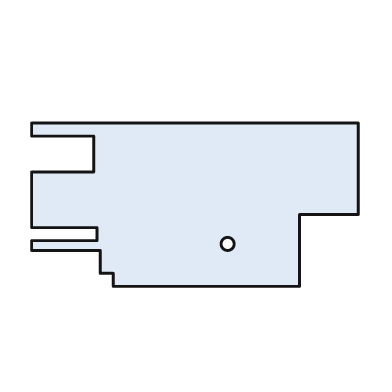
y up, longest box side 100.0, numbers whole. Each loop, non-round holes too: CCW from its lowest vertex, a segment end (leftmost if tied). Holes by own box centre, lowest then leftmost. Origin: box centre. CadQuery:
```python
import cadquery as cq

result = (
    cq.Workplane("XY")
    .moveTo(-25.0, -25.0)
    .lineTo(32.0, -25.0)
    .lineTo(32.0, -3.0)
    .lineTo(50.0, -3.0)
    .lineTo(50.0, 25.0)
    .lineTo(-50.0, 25.0)
    .lineTo(-50.0, 21.0)
    .lineTo(-31.0, 21.0)
    .lineTo(-31.0, 10.0)
    .lineTo(-50.0, 10.0)
    .lineTo(-50.0, -7.0)
    .lineTo(-30.0, -7.0)
    .lineTo(-30.0, -11.0)
    .lineTo(-50.0, -11.0)
    .lineTo(-50.0, -14.0)
    .lineTo(-29.0, -14.0)
    .lineTo(-29.0, -21.0)
    .lineTo(-25.0, -21.0)
    .close()
    .moveTo(10.0, -12.0)
    .circle(2.0)
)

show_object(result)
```